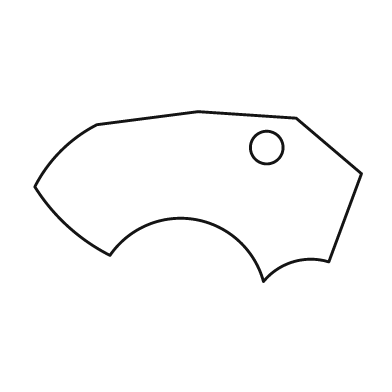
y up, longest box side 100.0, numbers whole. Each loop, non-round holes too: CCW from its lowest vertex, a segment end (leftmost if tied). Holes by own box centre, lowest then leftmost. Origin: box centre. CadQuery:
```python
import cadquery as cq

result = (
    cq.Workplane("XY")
    .moveTo(20.0, -26.0)
    .threePointArc((29.0, -20.0), (40.0, -20.0))
    .lineTo(50.0, 7.0)
    .lineTo(30.0, 24.0)
    .lineTo(0.0, 26.0)
    .lineTo(-31.0, 22.0)
    .threePointArc((-42.0, 14.0), (-50.0, 3.0))
    .threePointArc((-40.0, -9.0), (-27.0, -18.0))
    .threePointArc((-1.0, -7.0), (20.0, -26.0))
    .close()
    .moveTo(21.0, 15.0)
    .circle(5.0)
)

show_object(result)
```